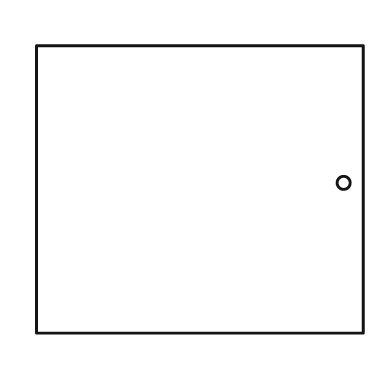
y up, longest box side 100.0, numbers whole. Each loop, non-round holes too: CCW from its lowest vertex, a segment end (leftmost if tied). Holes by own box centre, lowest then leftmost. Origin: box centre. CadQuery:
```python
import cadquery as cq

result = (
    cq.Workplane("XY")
    .moveTo(-50.0, -44.0)
    .lineTo(50.0, -44.0)
    .lineTo(50.0, 44.0)
    .lineTo(-50.0, 44.0)
    .close()
    .moveTo(44.0, 2.0)
    .circle(2.0)
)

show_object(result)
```